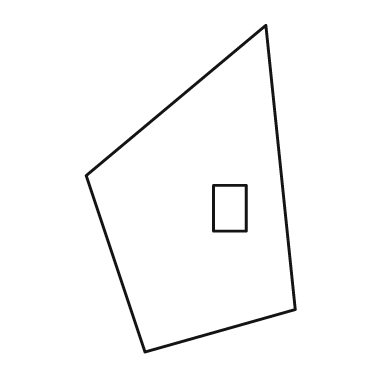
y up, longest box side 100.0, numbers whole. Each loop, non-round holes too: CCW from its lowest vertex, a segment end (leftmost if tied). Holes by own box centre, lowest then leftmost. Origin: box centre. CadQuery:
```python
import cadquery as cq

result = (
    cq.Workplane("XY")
    .moveTo(-14.0, -50.0)
    .lineTo(32.0, -37.0)
    .lineTo(23.0, 50.0)
    .lineTo(-32.0, 4.0)
    .close()
    .moveTo(7.0, -13.0)
    .lineTo(17.0, -13.0)
    .lineTo(17.0, 1.0)
    .lineTo(7.0, 1.0)
    .close()
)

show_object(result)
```